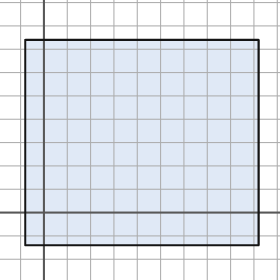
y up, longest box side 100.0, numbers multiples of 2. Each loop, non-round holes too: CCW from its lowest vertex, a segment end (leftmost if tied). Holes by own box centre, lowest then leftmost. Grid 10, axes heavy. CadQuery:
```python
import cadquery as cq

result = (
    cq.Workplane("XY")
    .moveTo(-8.0, -14.0)
    .lineTo(92.0, -14.0)
    .lineTo(92.0, 74.0)
    .lineTo(-8.0, 74.0)
    .close()
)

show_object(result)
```